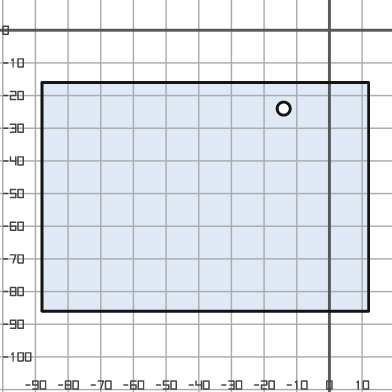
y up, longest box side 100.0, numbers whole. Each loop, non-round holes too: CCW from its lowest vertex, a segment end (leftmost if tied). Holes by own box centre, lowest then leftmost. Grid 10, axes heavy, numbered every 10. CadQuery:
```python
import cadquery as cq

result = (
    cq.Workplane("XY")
    .moveTo(-88.0, -86.0)
    .lineTo(12.0, -86.0)
    .lineTo(12.0, -16.0)
    .lineTo(-88.0, -16.0)
    .close()
    .moveTo(-14.0, -24.0)
    .circle(2.0)
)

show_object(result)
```